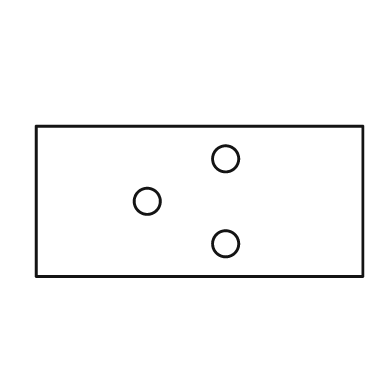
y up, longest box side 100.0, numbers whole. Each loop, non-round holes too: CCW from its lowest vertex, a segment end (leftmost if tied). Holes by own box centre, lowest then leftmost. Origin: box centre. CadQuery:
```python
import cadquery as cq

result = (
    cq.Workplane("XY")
    .moveTo(-50.0, -23.0)
    .lineTo(50.0, -23.0)
    .lineTo(50.0, 23.0)
    .lineTo(-50.0, 23.0)
    .close()
    .moveTo(8.0, -13.0)
    .circle(4.0)
    .moveTo(-16.0, 0.0)
    .circle(4.0)
    .moveTo(8.0, 13.0)
    .circle(4.0)
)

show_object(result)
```